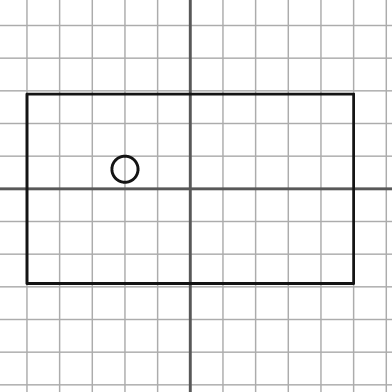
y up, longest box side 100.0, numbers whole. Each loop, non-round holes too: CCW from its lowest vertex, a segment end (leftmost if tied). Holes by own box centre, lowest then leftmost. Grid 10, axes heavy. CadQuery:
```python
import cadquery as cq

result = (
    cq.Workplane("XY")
    .moveTo(-50.0, -29.0)
    .lineTo(50.0, -29.0)
    .lineTo(50.0, 29.0)
    .lineTo(-50.0, 29.0)
    .close()
    .moveTo(-20.0, 6.0)
    .circle(4.0)
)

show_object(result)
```